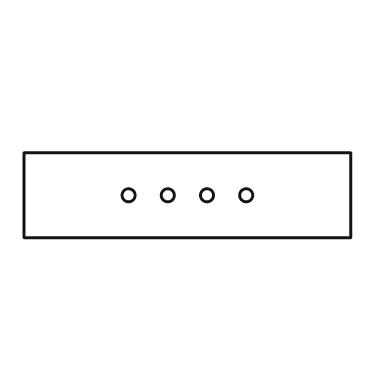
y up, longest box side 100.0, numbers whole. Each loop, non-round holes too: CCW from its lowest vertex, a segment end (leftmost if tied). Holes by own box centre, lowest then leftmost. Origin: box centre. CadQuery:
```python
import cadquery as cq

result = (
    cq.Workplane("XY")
    .moveTo(-50.0, -13.0)
    .lineTo(50.0, -13.0)
    .lineTo(50.0, 13.0)
    .lineTo(-50.0, 13.0)
    .close()
    .moveTo(-18.0, 0.0)
    .circle(2.0)
    .moveTo(-6.0, 0.0)
    .circle(2.0)
    .moveTo(6.0, 0.0)
    .circle(2.0)
    .moveTo(18.0, 0.0)
    .circle(2.0)
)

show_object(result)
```